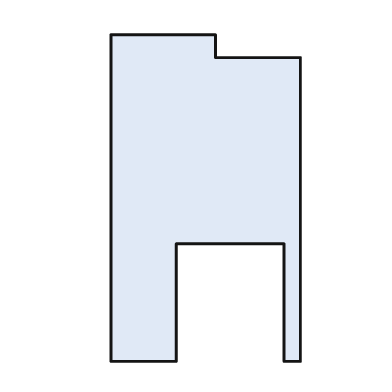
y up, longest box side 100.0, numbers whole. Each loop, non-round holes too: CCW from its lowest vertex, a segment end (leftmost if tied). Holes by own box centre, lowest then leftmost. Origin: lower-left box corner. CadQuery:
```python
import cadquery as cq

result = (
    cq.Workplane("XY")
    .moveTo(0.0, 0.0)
    .lineTo(20.0, 0.0)
    .lineTo(20.0, 36.0)
    .lineTo(53.0, 36.0)
    .lineTo(53.0, 0.0)
    .lineTo(58.0, 0.0)
    .lineTo(58.0, 93.0)
    .lineTo(32.0, 93.0)
    .lineTo(32.0, 100.0)
    .lineTo(0.0, 100.0)
    .close()
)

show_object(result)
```